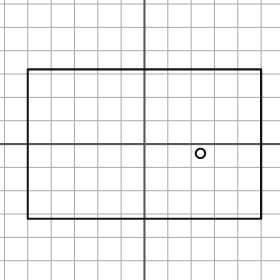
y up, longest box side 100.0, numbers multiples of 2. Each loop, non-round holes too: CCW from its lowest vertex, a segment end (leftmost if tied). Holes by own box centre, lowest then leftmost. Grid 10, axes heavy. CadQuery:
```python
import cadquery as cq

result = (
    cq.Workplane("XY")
    .moveTo(-50.0, -32.0)
    .lineTo(50.0, -32.0)
    .lineTo(50.0, 32.0)
    .lineTo(-50.0, 32.0)
    .close()
    .moveTo(24.0, -4.0)
    .circle(2.0)
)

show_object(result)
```